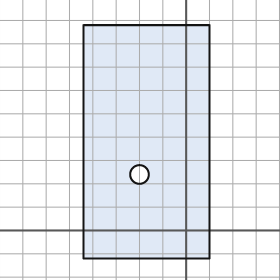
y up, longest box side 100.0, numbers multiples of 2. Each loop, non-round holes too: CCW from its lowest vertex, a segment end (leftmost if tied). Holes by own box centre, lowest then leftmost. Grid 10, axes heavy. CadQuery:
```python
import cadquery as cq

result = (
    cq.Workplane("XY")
    .moveTo(-44.0, -12.0)
    .lineTo(10.0, -12.0)
    .lineTo(10.0, 88.0)
    .lineTo(-44.0, 88.0)
    .close()
    .moveTo(-20.0, 24.0)
    .circle(4.0)
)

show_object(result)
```